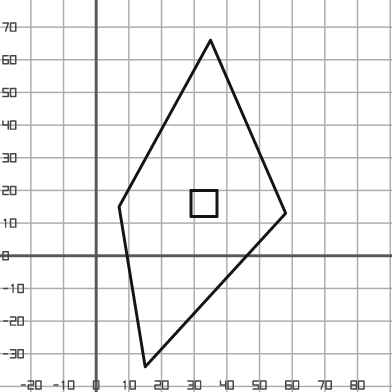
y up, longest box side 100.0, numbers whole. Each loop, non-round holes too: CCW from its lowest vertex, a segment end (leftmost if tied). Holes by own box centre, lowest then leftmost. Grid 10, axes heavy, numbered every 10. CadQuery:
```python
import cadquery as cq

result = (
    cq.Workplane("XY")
    .moveTo(15.0, -34.0)
    .lineTo(58.0, 13.0)
    .lineTo(35.0, 66.0)
    .lineTo(7.0, 15.0)
    .close()
    .moveTo(29.0, 12.0)
    .lineTo(37.0, 12.0)
    .lineTo(37.0, 20.0)
    .lineTo(29.0, 20.0)
    .close()
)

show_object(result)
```